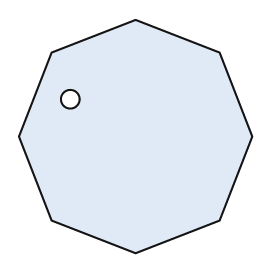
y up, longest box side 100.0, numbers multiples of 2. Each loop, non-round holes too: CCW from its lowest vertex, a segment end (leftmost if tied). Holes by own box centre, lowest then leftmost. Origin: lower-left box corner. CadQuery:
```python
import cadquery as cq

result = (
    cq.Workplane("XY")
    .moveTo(50.0, 0.0)
    .lineTo(86.0, 14.0)
    .lineTo(100.0, 50.0)
    .lineTo(86.0, 86.0)
    .lineTo(50.0, 100.0)
    .lineTo(14.0, 86.0)
    .lineTo(0.0, 50.0)
    .lineTo(14.0, 14.0)
    .close()
    .moveTo(22.0, 66.0)
    .circle(4.0)
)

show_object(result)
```